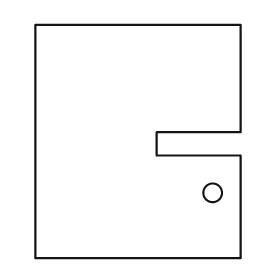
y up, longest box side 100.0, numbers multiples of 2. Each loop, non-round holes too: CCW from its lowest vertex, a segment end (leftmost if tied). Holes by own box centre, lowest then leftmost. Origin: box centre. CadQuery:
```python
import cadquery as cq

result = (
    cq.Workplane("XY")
    .moveTo(-44.0, -50.0)
    .lineTo(44.0, -50.0)
    .lineTo(44.0, -6.0)
    .lineTo(8.0, -6.0)
    .lineTo(8.0, 4.0)
    .lineTo(44.0, 4.0)
    .lineTo(44.0, 50.0)
    .lineTo(-44.0, 50.0)
    .close()
    .moveTo(32.0, -22.0)
    .circle(4.0)
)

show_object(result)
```